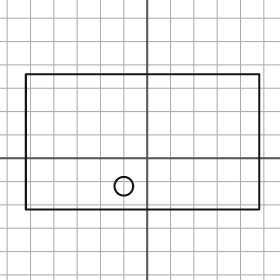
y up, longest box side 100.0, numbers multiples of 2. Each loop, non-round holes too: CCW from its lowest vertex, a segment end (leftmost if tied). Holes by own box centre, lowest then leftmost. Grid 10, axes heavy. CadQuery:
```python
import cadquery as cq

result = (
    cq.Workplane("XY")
    .moveTo(-52.0, -22.0)
    .lineTo(48.0, -22.0)
    .lineTo(48.0, 36.0)
    .lineTo(-52.0, 36.0)
    .close()
    .moveTo(-10.0, -12.0)
    .circle(4.0)
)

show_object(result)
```